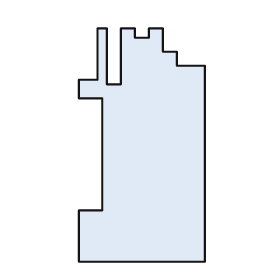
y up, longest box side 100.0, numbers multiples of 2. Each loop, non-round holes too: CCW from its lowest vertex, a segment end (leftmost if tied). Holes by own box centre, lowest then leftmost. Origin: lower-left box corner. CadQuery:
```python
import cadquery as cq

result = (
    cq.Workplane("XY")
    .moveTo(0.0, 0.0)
    .lineTo(54.0, 0.0)
    .lineTo(54.0, 84.0)
    .lineTo(42.0, 84.0)
    .lineTo(42.0, 90.0)
    .lineTo(36.0, 90.0)
    .lineTo(36.0, 100.0)
    .lineTo(30.0, 100.0)
    .lineTo(30.0, 96.0)
    .lineTo(24.0, 96.0)
    .lineTo(24.0, 100.0)
    .lineTo(18.0, 100.0)
    .lineTo(18.0, 76.0)
    .lineTo(12.0, 76.0)
    .lineTo(12.0, 100.0)
    .lineTo(8.0, 100.0)
    .lineTo(8.0, 78.0)
    .lineTo(0.0, 78.0)
    .lineTo(0.0, 70.0)
    .lineTo(10.0, 70.0)
    .lineTo(10.0, 22.0)
    .lineTo(0.0, 22.0)
    .close()
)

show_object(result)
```